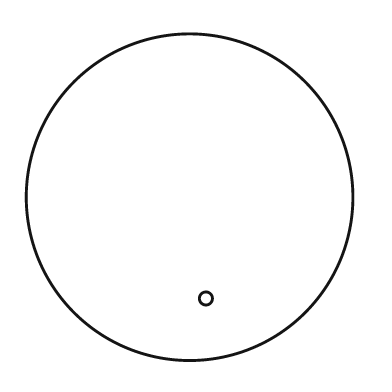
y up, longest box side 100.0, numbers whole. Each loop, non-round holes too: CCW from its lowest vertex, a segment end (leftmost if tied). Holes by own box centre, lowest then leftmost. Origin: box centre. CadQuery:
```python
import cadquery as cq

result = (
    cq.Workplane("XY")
    .moveTo(0.0, 0.0)
    .circle(50.0)
    .moveTo(5.0, -31.0)
    .circle(2.0)
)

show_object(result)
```